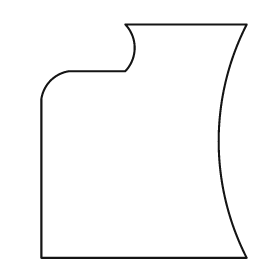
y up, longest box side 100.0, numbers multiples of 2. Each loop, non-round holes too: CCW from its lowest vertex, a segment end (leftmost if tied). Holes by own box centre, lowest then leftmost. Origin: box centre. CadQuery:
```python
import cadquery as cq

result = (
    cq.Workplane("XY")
    .moveTo(-44.0, -50.0)
    .lineTo(44.0, -50.0)
    .threePointArc((32.0, 0.0), (44.0, 50.0))
    .lineTo(-8.0, 50.0)
    .threePointArc((-4.0, 40.0), (-8.0, 30.0))
    .lineTo(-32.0, 30.0)
    .threePointArc((-40.0, 26.0), (-44.0, 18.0))
    .close()
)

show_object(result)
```